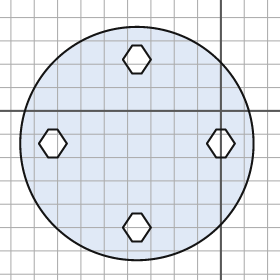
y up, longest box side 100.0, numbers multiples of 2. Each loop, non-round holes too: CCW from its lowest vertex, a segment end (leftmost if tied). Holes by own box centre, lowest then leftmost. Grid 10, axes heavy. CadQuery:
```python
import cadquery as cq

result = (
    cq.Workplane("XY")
    .moveTo(-36.0, -14.0)
    .circle(50.0)
    .moveTo(-38.0, -56.0)
    .lineTo(-34.0, -56.0)
    .lineTo(-30.0, -50.0)
    .lineTo(-34.0, -44.0)
    .lineTo(-38.0, -44.0)
    .lineTo(-42.0, -50.0)
    .close()
    .moveTo(-74.0, -20.0)
    .lineTo(-70.0, -20.0)
    .lineTo(-66.0, -14.0)
    .lineTo(-70.0, -8.0)
    .lineTo(-74.0, -8.0)
    .lineTo(-78.0, -14.0)
    .close()
    .moveTo(-2.0, -20.0)
    .lineTo(2.0, -20.0)
    .lineTo(6.0, -14.0)
    .lineTo(2.0, -8.0)
    .lineTo(-2.0, -8.0)
    .lineTo(-6.0, -14.0)
    .close()
    .moveTo(-38.0, 16.0)
    .lineTo(-34.0, 16.0)
    .lineTo(-30.0, 22.0)
    .lineTo(-34.0, 28.0)
    .lineTo(-38.0, 28.0)
    .lineTo(-42.0, 22.0)
    .close()
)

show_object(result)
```